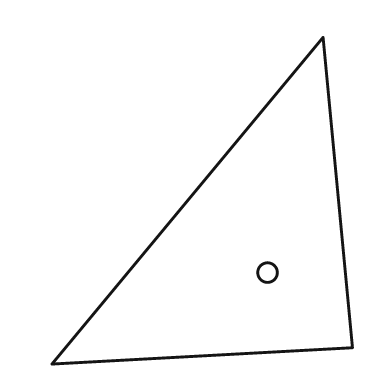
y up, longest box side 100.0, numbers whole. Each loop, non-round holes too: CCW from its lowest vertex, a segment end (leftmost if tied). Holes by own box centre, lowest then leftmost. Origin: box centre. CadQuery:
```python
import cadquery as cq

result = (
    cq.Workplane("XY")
    .moveTo(-46.0, -50.0)
    .lineTo(46.0, -45.0)
    .lineTo(37.0, 50.0)
    .close()
    .moveTo(20.0, -22.0)
    .circle(3.0)
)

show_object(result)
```